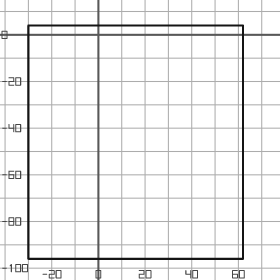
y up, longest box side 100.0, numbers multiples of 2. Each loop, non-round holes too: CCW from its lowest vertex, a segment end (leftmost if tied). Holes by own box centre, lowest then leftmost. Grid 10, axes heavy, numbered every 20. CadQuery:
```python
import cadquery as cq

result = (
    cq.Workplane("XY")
    .moveTo(-30.0, -96.0)
    .lineTo(62.0, -96.0)
    .lineTo(62.0, 4.0)
    .lineTo(-30.0, 4.0)
    .close()
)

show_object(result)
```